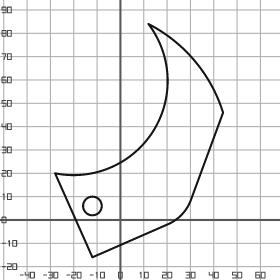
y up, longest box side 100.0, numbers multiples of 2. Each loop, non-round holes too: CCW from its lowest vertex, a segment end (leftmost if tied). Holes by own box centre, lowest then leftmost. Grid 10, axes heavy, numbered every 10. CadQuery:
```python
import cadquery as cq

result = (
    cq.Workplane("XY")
    .moveTo(-12.0, -16.0)
    .lineTo(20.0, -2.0)
    .threePointArc((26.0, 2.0), (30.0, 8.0))
    .lineTo(44.0, 46.0)
    .threePointArc((32.0, 68.0), (12.0, 84.0))
    .threePointArc((14.0, 38.0), (-28.0, 20.0))
    .close()
    .moveTo(-12.0, 6.0)
    .circle(4.0)
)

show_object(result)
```